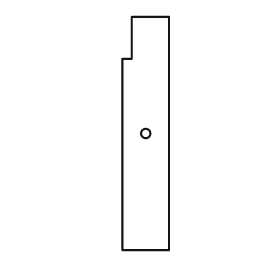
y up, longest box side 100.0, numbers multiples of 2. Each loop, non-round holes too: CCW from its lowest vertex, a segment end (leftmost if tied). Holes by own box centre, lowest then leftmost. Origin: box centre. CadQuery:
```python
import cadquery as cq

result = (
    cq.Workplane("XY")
    .moveTo(-10.0, -50.0)
    .lineTo(10.0, -50.0)
    .lineTo(10.0, 50.0)
    .lineTo(-6.0, 50.0)
    .lineTo(-6.0, 32.0)
    .lineTo(-10.0, 32.0)
    .close()
    .moveTo(0.0, 0.0)
    .circle(2.0)
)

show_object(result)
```